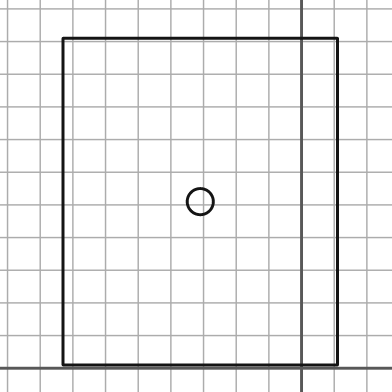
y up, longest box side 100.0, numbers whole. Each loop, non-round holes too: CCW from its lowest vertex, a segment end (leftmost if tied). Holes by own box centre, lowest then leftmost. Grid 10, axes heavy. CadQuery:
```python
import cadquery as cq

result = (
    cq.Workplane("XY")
    .moveTo(-73.0, 1.0)
    .lineTo(11.0, 1.0)
    .lineTo(11.0, 101.0)
    .lineTo(-73.0, 101.0)
    .close()
    .moveTo(-31.0, 51.0)
    .circle(4.0)
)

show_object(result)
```